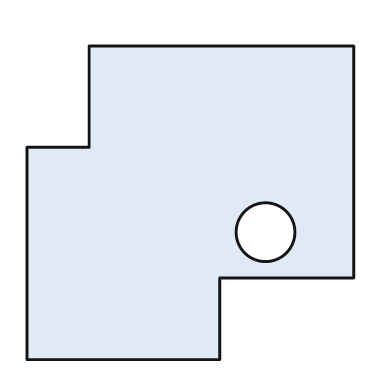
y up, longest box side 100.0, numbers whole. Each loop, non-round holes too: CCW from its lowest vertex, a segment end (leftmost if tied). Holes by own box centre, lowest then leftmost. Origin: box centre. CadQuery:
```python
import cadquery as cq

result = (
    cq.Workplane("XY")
    .moveTo(-50.0, -48.0)
    .lineTo(9.0, -48.0)
    .lineTo(9.0, -23.0)
    .lineTo(50.0, -23.0)
    .lineTo(50.0, 48.0)
    .lineTo(-31.0, 48.0)
    .lineTo(-31.0, 17.0)
    .lineTo(-50.0, 17.0)
    .close()
    .moveTo(23.0, -9.0)
    .circle(9.0)
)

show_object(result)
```